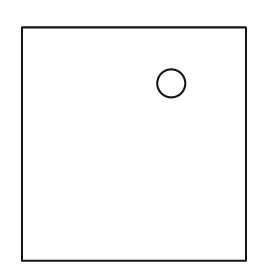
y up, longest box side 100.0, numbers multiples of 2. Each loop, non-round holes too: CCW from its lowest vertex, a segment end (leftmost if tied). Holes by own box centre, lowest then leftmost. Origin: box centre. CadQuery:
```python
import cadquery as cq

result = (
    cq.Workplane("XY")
    .moveTo(-48.0, -50.0)
    .lineTo(48.0, -50.0)
    .lineTo(48.0, 50.0)
    .lineTo(-48.0, 50.0)
    .close()
    .moveTo(16.0, 26.0)
    .circle(6.0)
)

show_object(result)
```